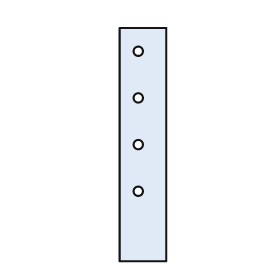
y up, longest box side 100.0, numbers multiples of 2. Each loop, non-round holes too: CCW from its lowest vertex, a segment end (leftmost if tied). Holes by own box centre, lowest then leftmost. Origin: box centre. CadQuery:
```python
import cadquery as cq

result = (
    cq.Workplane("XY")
    .moveTo(-10.0, -50.0)
    .lineTo(10.0, -50.0)
    .lineTo(10.0, 50.0)
    .lineTo(-10.0, 50.0)
    .close()
    .moveTo(-2.0, -20.0)
    .circle(2.0)
    .moveTo(-2.0, 0.0)
    .circle(2.0)
    .moveTo(-2.0, 20.0)
    .circle(2.0)
    .moveTo(-2.0, 40.0)
    .circle(2.0)
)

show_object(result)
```